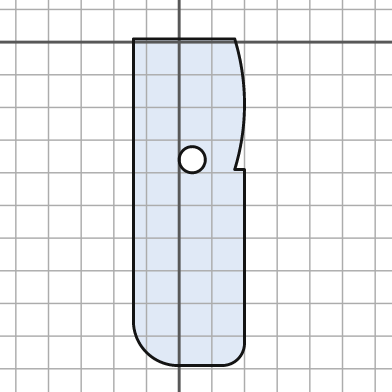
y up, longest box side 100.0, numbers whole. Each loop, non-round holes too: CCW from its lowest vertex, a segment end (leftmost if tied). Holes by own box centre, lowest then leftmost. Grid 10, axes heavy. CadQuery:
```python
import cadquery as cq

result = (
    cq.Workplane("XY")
    .moveTo(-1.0, -99.0)
    .lineTo(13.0, -99.0)
    .threePointArc((18.0, -97.0), (20.0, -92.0))
    .lineTo(20.0, -39.0)
    .lineTo(17.0, -39.0)
    .threePointArc((20.0, -19.0), (17.0, 1.0))
    .lineTo(-14.0, 1.0)
    .lineTo(-14.0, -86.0)
    .threePointArc((-10.0, -95.0), (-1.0, -99.0))
    .close()
    .moveTo(4.0, -36.0)
    .circle(4.0)
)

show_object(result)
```